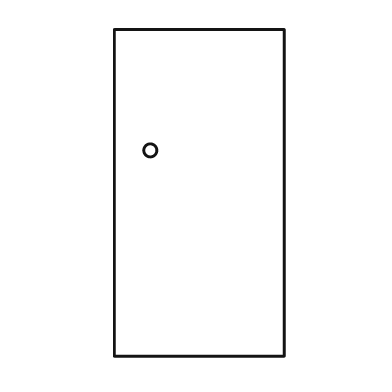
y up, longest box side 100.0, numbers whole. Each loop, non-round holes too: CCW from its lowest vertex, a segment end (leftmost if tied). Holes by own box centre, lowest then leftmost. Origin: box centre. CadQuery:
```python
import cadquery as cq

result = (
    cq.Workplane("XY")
    .moveTo(-26.0, -50.0)
    .lineTo(26.0, -50.0)
    .lineTo(26.0, 50.0)
    .lineTo(-26.0, 50.0)
    .close()
    .moveTo(-15.0, 13.0)
    .circle(2.0)
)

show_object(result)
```